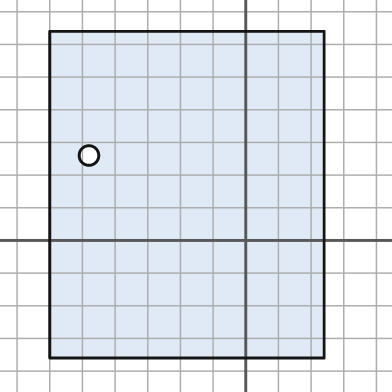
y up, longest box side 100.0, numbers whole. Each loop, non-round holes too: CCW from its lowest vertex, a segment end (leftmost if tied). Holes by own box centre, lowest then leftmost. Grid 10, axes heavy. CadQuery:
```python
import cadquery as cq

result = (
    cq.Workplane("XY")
    .moveTo(-60.0, -36.0)
    .lineTo(24.0, -36.0)
    .lineTo(24.0, 64.0)
    .lineTo(-60.0, 64.0)
    .close()
    .moveTo(-48.0, 26.0)
    .circle(3.0)
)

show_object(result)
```